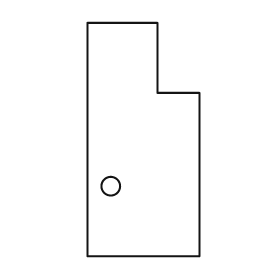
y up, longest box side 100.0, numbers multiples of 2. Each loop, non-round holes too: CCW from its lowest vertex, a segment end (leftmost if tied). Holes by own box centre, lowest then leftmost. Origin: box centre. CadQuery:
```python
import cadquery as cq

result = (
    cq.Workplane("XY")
    .moveTo(-24.0, -50.0)
    .lineTo(24.0, -50.0)
    .lineTo(24.0, 20.0)
    .lineTo(6.0, 20.0)
    .lineTo(6.0, 50.0)
    .lineTo(-24.0, 50.0)
    .close()
    .moveTo(-14.0, -20.0)
    .circle(4.0)
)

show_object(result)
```